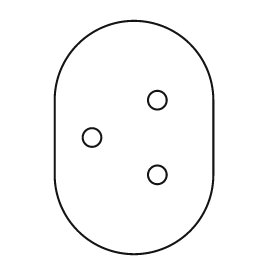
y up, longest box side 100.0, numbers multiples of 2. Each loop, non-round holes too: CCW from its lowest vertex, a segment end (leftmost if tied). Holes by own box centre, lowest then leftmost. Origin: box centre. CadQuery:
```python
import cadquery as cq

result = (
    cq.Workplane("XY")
    .moveTo(-34.0, -16.0)
    .threePointArc((0.0, -50.0), (34.0, -16.0))
    .lineTo(34.0, 16.0)
    .threePointArc((0.0, 50.0), (-34.0, 16.0))
    .close()
    .moveTo(10.0, -16.0)
    .circle(4.0)
    .moveTo(-18.0, 0.0)
    .circle(4.0)
    .moveTo(10.0, 16.0)
    .circle(4.0)
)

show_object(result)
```